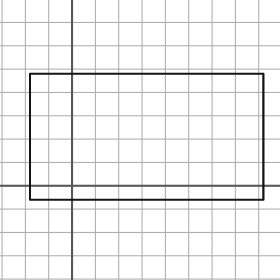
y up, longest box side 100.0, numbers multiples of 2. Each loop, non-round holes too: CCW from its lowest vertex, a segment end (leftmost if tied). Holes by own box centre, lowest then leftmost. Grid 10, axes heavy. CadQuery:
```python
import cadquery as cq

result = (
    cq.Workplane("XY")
    .moveTo(-18.0, -6.0)
    .lineTo(82.0, -6.0)
    .lineTo(82.0, 48.0)
    .lineTo(-18.0, 48.0)
    .close()
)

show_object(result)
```